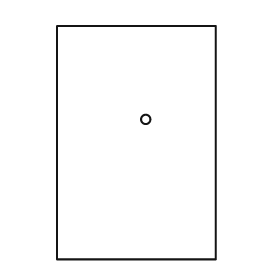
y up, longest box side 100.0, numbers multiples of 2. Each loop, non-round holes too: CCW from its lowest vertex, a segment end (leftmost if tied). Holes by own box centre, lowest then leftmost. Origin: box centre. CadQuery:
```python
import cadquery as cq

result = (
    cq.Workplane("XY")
    .moveTo(-34.0, -50.0)
    .lineTo(34.0, -50.0)
    .lineTo(34.0, 50.0)
    .lineTo(-34.0, 50.0)
    .close()
    .moveTo(4.0, 10.0)
    .circle(2.0)
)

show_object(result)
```